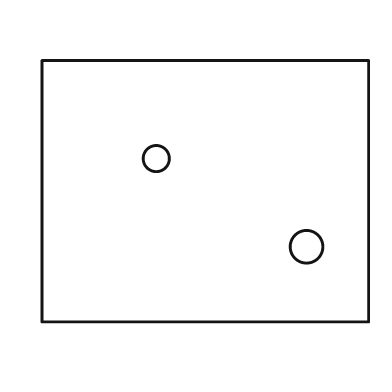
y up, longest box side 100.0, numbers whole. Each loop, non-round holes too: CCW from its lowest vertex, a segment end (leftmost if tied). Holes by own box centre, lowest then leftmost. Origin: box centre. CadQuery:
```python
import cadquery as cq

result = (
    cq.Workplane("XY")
    .moveTo(-50.0, -40.0)
    .lineTo(50.0, -40.0)
    .lineTo(50.0, 40.0)
    .lineTo(-50.0, 40.0)
    .close()
    .moveTo(31.0, -17.0)
    .circle(5.0)
    .moveTo(-15.0, 10.0)
    .circle(4.0)
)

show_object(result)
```